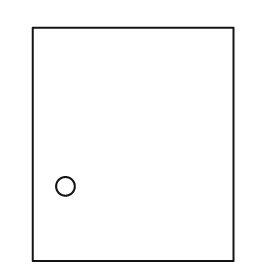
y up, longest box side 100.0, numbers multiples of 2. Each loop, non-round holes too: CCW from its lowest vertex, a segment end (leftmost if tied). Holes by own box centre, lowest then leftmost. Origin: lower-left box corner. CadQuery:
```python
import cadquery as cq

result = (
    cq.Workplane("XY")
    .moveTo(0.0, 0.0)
    .lineTo(86.0, 0.0)
    .lineTo(86.0, 100.0)
    .lineTo(0.0, 100.0)
    .close()
    .moveTo(14.0, 32.0)
    .circle(4.0)
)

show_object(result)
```